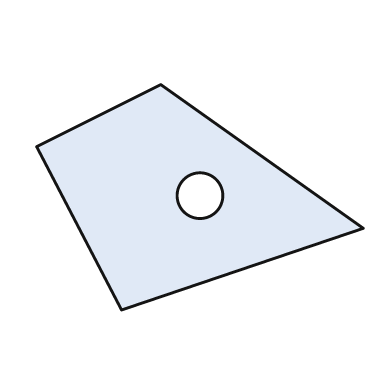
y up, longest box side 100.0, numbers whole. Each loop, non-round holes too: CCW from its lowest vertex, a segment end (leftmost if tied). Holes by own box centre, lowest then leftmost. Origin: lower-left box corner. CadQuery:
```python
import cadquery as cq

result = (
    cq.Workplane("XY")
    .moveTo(26.0, 0.0)
    .lineTo(100.0, 25.0)
    .lineTo(38.0, 69.0)
    .lineTo(0.0, 50.0)
    .close()
    .moveTo(50.0, 35.0)
    .circle(7.0)
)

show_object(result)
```